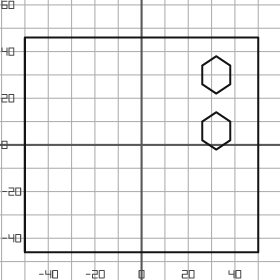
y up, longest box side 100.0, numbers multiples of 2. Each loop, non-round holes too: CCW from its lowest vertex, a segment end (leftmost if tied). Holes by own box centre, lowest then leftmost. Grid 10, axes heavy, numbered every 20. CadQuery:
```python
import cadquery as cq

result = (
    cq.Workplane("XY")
    .moveTo(-50.0, -46.0)
    .lineTo(50.0, -46.0)
    .lineTo(50.0, 46.0)
    .lineTo(-50.0, 46.0)
    .close()
    .moveTo(32.0, -2.0)
    .lineTo(38.0, 2.0)
    .lineTo(38.0, 10.0)
    .lineTo(32.0, 14.0)
    .lineTo(26.0, 10.0)
    .lineTo(26.0, 2.0)
    .close()
    .moveTo(32.0, 22.0)
    .lineTo(38.0, 26.0)
    .lineTo(38.0, 34.0)
    .lineTo(32.0, 38.0)
    .lineTo(26.0, 34.0)
    .lineTo(26.0, 26.0)
    .close()
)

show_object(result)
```